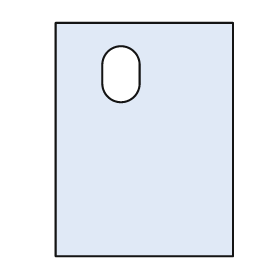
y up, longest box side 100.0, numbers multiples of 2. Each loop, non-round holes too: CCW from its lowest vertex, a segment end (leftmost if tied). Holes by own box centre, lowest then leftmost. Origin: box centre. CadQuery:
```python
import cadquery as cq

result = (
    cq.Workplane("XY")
    .moveTo(-38.0, -50.0)
    .lineTo(38.0, -50.0)
    .lineTo(38.0, 50.0)
    .lineTo(-38.0, 50.0)
    .close()
    .moveTo(-18.0, 24.0)
    .threePointArc((-10.0, 16.0), (-2.0, 24.0))
    .lineTo(-2.0, 32.0)
    .threePointArc((-10.0, 40.0), (-18.0, 32.0))
    .close()
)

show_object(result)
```